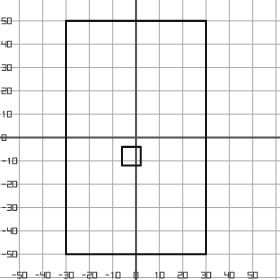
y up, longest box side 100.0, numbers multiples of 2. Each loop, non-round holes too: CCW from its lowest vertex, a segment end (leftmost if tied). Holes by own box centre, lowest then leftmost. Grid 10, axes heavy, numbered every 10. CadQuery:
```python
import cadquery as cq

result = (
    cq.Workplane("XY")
    .moveTo(-30.0, -50.0)
    .lineTo(30.0, -50.0)
    .lineTo(30.0, 50.0)
    .lineTo(-30.0, 50.0)
    .close()
    .moveTo(-6.0, -12.0)
    .lineTo(2.0, -12.0)
    .lineTo(2.0, -4.0)
    .lineTo(-6.0, -4.0)
    .close()
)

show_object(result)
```